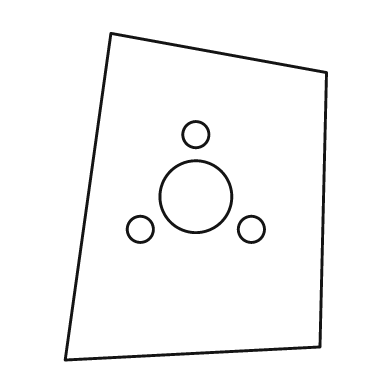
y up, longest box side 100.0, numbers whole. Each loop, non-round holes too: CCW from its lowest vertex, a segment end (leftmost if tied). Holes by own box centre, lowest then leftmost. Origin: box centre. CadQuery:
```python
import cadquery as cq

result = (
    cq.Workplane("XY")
    .moveTo(-40.0, -50.0)
    .lineTo(38.0, -46.0)
    .lineTo(40.0, 38.0)
    .lineTo(-26.0, 50.0)
    .close()
    .moveTo(-17.0, -10.0)
    .circle(4.0)
    .moveTo(17.0, -10.0)
    .circle(4.0)
    .moveTo(0.0, 0.0)
    .circle(11.0)
    .moveTo(0.0, 19.0)
    .circle(4.0)
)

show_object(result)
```